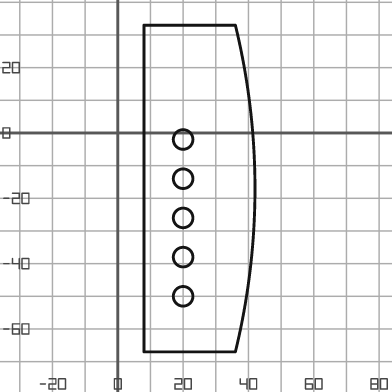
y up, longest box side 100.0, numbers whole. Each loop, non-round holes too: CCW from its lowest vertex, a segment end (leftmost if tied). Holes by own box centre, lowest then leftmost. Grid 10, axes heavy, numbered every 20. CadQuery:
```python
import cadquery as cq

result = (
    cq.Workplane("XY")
    .moveTo(8.0, -67.0)
    .lineTo(36.0, -67.0)
    .threePointArc((42.0, -17.0), (36.0, 33.0))
    .lineTo(8.0, 33.0)
    .close()
    .moveTo(20.0, -50.0)
    .circle(3.0)
    .moveTo(20.0, -38.0)
    .circle(3.0)
    .moveTo(20.0, -26.0)
    .circle(3.0)
    .moveTo(20.0, -14.0)
    .circle(3.0)
    .moveTo(20.0, -2.0)
    .circle(3.0)
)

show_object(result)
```